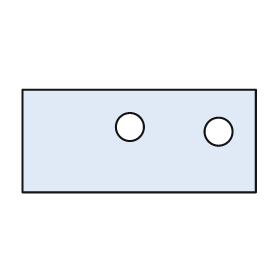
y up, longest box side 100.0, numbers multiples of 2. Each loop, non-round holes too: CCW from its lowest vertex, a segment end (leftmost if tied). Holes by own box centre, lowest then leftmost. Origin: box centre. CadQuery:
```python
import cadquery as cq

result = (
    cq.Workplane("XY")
    .moveTo(-50.0, -22.0)
    .lineTo(50.0, -22.0)
    .lineTo(50.0, 22.0)
    .lineTo(-50.0, 22.0)
    .close()
    .moveTo(34.0, 4.0)
    .circle(6.0)
    .moveTo(-4.0, 6.0)
    .circle(6.0)
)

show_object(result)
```